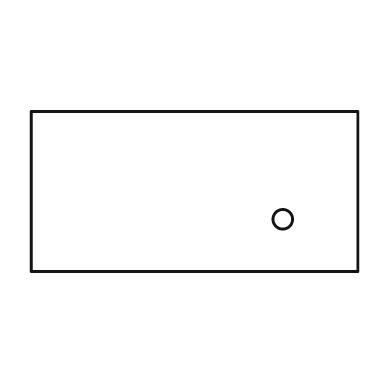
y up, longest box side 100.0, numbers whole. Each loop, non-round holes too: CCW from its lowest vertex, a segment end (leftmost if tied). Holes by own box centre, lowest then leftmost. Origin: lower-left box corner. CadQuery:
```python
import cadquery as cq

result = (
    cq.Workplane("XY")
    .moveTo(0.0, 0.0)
    .lineTo(100.0, 0.0)
    .lineTo(100.0, 49.0)
    .lineTo(0.0, 49.0)
    .close()
    .moveTo(77.0, 16.0)
    .circle(3.0)
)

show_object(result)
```